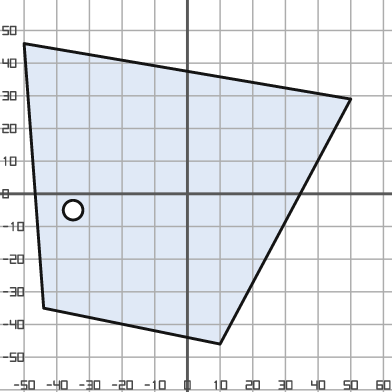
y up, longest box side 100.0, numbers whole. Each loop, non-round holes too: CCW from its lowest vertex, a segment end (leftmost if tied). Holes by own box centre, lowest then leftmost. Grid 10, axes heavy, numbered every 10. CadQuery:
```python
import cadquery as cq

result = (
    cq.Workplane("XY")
    .moveTo(10.0, -46.0)
    .lineTo(50.0, 29.0)
    .lineTo(-50.0, 46.0)
    .lineTo(-44.0, -35.0)
    .close()
    .moveTo(-35.0, -5.0)
    .circle(3.0)
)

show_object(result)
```